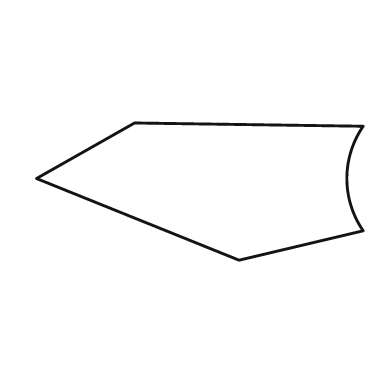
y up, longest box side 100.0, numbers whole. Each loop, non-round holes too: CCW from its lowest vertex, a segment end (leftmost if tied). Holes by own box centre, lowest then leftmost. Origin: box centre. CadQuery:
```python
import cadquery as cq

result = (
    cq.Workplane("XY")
    .moveTo(12.0, -21.0)
    .lineTo(50.0, -12.0)
    .threePointArc((45.0, 4.0), (50.0, 20.0))
    .lineTo(-20.0, 21.0)
    .lineTo(-50.0, 4.0)
    .close()
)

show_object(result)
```